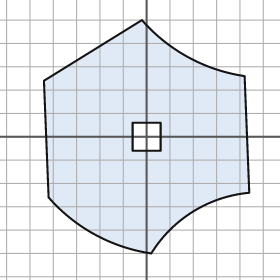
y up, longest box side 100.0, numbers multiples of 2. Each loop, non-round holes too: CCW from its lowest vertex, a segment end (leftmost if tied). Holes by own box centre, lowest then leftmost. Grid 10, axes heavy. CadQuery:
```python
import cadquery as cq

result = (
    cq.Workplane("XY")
    .moveTo(2.0, -50.0)
    .threePointArc((20.0, -32.0), (44.0, -24.0))
    .lineTo(42.0, 26.0)
    .threePointArc((18.0, 34.0), (-2.0, 50.0))
    .lineTo(-44.0, 24.0)
    .lineTo(-42.0, -26.0)
    .threePointArc((-22.0, -42.0), (2.0, -50.0))
    .close()
    .moveTo(-6.0, -6.0)
    .lineTo(6.0, -6.0)
    .lineTo(6.0, 6.0)
    .lineTo(-6.0, 6.0)
    .close()
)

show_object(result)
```